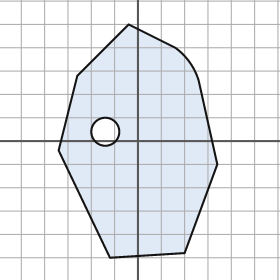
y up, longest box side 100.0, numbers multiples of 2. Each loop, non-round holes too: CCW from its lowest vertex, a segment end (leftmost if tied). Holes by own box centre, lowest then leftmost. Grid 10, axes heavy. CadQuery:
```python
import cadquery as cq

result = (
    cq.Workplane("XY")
    .moveTo(-12.0, -50.0)
    .lineTo(20.0, -48.0)
    .lineTo(34.0, -10.0)
    .lineTo(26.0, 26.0)
    .threePointArc((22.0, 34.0), (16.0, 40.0))
    .lineTo(-4.0, 50.0)
    .lineTo(-26.0, 28.0)
    .lineTo(-34.0, -4.0)
    .close()
    .moveTo(-14.0, 4.0)
    .circle(6.0)
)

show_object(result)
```